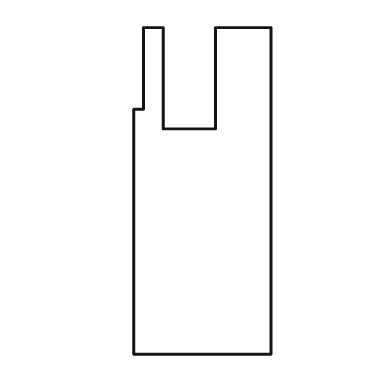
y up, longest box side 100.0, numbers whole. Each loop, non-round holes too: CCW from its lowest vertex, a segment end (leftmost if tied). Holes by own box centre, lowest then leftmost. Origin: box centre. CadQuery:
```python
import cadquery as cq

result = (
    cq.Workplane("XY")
    .moveTo(-21.0, -50.0)
    .lineTo(21.0, -50.0)
    .lineTo(21.0, 50.0)
    .lineTo(4.0, 50.0)
    .lineTo(4.0, 19.0)
    .lineTo(-12.0, 19.0)
    .lineTo(-12.0, 50.0)
    .lineTo(-18.0, 50.0)
    .lineTo(-18.0, 25.0)
    .lineTo(-21.0, 25.0)
    .close()
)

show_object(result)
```